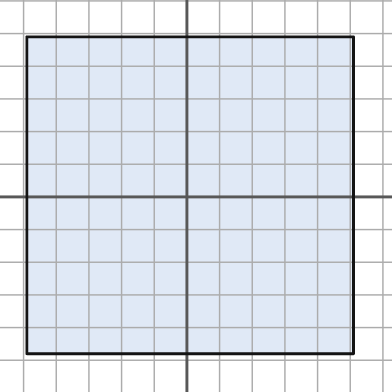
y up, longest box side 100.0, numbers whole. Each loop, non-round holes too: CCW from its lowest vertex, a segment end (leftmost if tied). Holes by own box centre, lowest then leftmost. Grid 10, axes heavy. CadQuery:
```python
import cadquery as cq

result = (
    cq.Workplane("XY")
    .moveTo(-49.0, -48.0)
    .lineTo(51.0, -48.0)
    .lineTo(51.0, 49.0)
    .lineTo(-49.0, 49.0)
    .close()
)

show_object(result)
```